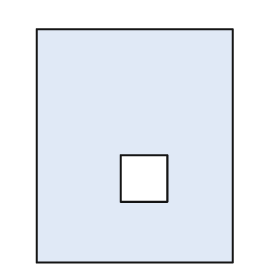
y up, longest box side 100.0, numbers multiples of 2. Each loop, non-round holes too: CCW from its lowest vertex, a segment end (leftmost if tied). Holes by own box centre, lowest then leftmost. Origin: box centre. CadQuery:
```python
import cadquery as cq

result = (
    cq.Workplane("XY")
    .moveTo(-42.0, -50.0)
    .lineTo(42.0, -50.0)
    .lineTo(42.0, 50.0)
    .lineTo(-42.0, 50.0)
    .close()
    .moveTo(-6.0, -24.0)
    .lineTo(14.0, -24.0)
    .lineTo(14.0, -4.0)
    .lineTo(-6.0, -4.0)
    .close()
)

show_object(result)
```